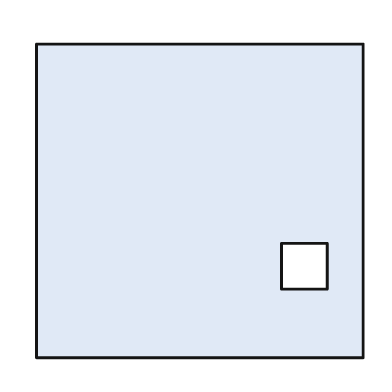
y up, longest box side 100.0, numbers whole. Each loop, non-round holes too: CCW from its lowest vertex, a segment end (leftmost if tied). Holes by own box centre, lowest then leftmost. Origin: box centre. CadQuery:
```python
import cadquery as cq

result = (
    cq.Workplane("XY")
    .moveTo(-50.0, -48.0)
    .lineTo(50.0, -48.0)
    .lineTo(50.0, 48.0)
    .lineTo(-50.0, 48.0)
    .close()
    .moveTo(25.0, -27.0)
    .lineTo(39.0, -27.0)
    .lineTo(39.0, -13.0)
    .lineTo(25.0, -13.0)
    .close()
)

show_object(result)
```